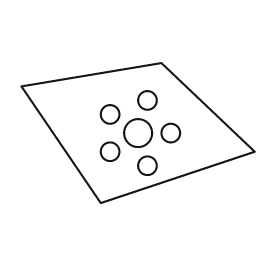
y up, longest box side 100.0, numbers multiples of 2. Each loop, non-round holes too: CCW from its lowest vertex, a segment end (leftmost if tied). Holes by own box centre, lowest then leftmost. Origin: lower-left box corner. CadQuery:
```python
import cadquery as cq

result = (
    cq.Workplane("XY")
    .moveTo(34.0, 0.0)
    .lineTo(100.0, 22.0)
    .lineTo(60.0, 60.0)
    .lineTo(0.0, 50.0)
    .close()
    .moveTo(54.0, 16.0)
    .circle(4.0)
    .moveTo(38.0, 22.0)
    .circle(4.0)
    .moveTo(50.0, 30.0)
    .circle(6.0)
    .moveTo(64.0, 30.0)
    .circle(4.0)
    .moveTo(38.0, 38.0)
    .circle(4.0)
    .moveTo(54.0, 44.0)
    .circle(4.0)
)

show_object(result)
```